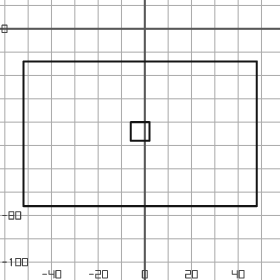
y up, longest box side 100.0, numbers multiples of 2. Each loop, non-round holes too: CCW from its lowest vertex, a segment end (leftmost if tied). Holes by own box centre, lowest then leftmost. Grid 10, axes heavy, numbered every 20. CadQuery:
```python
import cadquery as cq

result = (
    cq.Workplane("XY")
    .moveTo(-52.0, -76.0)
    .lineTo(48.0, -76.0)
    .lineTo(48.0, -14.0)
    .lineTo(-52.0, -14.0)
    .close()
    .moveTo(-6.0, -48.0)
    .lineTo(2.0, -48.0)
    .lineTo(2.0, -40.0)
    .lineTo(-6.0, -40.0)
    .close()
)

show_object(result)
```